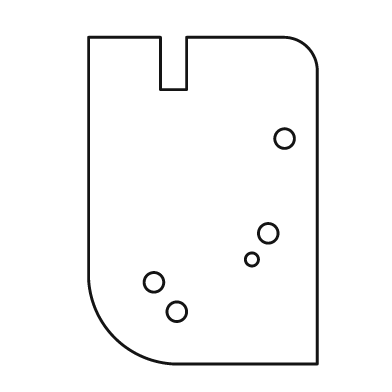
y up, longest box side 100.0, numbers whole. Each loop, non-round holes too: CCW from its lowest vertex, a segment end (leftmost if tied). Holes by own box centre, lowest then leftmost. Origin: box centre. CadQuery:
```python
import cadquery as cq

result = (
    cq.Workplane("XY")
    .moveTo(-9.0, -50.0)
    .lineTo(35.0, -50.0)
    .lineTo(35.0, 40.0)
    .threePointArc((32.0, 47.0), (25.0, 50.0))
    .lineTo(-5.0, 50.0)
    .lineTo(-5.0, 34.0)
    .lineTo(-13.0, 34.0)
    .lineTo(-13.0, 50.0)
    .lineTo(-35.0, 50.0)
    .lineTo(-35.0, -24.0)
    .threePointArc((-27.0, -42.0), (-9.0, -50.0))
    .close()
    .moveTo(-8.0, -34.0)
    .circle(3.0)
    .moveTo(-15.0, -25.0)
    .circle(3.0)
    .moveTo(15.0, -18.0)
    .circle(2.0)
    .moveTo(20.0, -10.0)
    .circle(3.0)
    .moveTo(25.0, 19.0)
    .circle(3.0)
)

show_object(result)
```